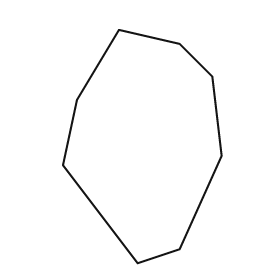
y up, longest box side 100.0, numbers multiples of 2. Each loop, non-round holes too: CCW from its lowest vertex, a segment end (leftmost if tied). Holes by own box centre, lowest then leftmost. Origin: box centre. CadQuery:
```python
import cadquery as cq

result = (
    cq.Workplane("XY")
    .moveTo(-2.0, -50.0)
    .lineTo(16.0, -44.0)
    .lineTo(34.0, -4.0)
    .lineTo(30.0, 30.0)
    .lineTo(16.0, 44.0)
    .lineTo(-10.0, 50.0)
    .lineTo(-28.0, 20.0)
    .lineTo(-34.0, -8.0)
    .close()
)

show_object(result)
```